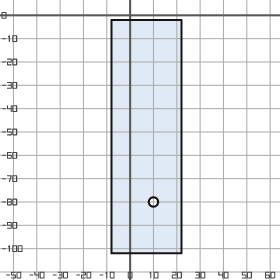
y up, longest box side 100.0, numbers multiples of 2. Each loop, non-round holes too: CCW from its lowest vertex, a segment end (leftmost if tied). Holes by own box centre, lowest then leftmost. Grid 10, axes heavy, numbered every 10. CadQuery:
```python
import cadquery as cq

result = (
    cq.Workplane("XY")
    .moveTo(-8.0, -102.0)
    .lineTo(22.0, -102.0)
    .lineTo(22.0, -2.0)
    .lineTo(-8.0, -2.0)
    .close()
    .moveTo(10.0, -80.0)
    .circle(2.0)
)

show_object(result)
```